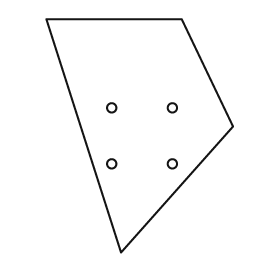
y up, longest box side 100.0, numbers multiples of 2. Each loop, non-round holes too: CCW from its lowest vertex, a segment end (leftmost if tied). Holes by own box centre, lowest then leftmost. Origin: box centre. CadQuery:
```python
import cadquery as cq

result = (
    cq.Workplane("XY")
    .moveTo(-8.0, -50.0)
    .lineTo(40.0, 4.0)
    .lineTo(18.0, 50.0)
    .lineTo(-40.0, 50.0)
    .close()
    .moveTo(-12.0, -12.0)
    .circle(2.0)
    .moveTo(14.0, -12.0)
    .circle(2.0)
    .moveTo(-12.0, 12.0)
    .circle(2.0)
    .moveTo(14.0, 12.0)
    .circle(2.0)
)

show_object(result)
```